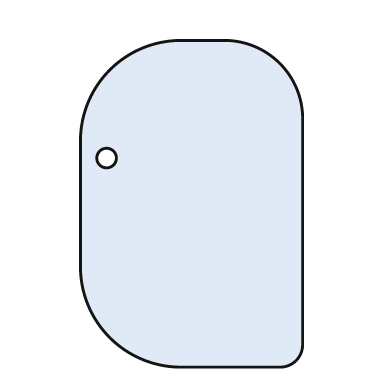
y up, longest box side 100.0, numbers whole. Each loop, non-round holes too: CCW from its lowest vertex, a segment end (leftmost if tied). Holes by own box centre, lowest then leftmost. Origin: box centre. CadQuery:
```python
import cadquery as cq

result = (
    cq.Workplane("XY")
    .moveTo(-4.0, -50.0)
    .lineTo(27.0, -50.0)
    .threePointArc((32.0, -48.0), (34.0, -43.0))
    .lineTo(34.0, 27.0)
    .threePointArc((27.0, 43.0), (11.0, 50.0))
    .lineTo(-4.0, 50.0)
    .threePointArc((-25.0, 41.0), (-34.0, 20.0))
    .lineTo(-34.0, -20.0)
    .threePointArc((-25.0, -41.0), (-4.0, -50.0))
    .close()
    .moveTo(-26.0, 14.0)
    .circle(3.0)
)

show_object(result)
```